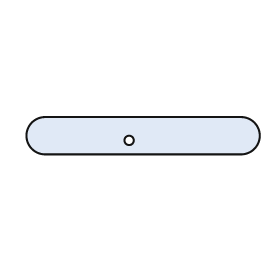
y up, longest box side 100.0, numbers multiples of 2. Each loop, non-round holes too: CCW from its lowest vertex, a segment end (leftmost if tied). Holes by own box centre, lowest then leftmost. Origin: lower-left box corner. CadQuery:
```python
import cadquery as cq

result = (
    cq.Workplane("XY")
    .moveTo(8.0, 0.0)
    .lineTo(92.0, 0.0)
    .threePointArc((100.0, 8.0), (92.0, 16.0))
    .lineTo(8.0, 16.0)
    .threePointArc((0.0, 8.0), (8.0, 0.0))
    .close()
    .moveTo(44.0, 6.0)
    .circle(2.0)
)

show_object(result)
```